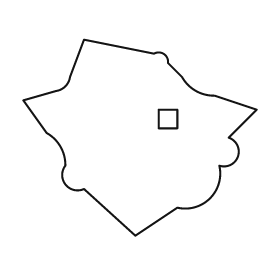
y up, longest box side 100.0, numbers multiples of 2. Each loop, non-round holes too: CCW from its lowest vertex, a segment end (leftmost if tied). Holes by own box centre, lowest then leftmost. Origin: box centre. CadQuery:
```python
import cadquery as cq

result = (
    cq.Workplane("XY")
    .moveTo(-2.0, -42.0)
    .lineTo(16.0, -30.0)
    .threePointArc((30.0, -26.0), (34.0, -12.0))
    .threePointArc((42.0, -8.0), (38.0, 0.0))
    .lineTo(50.0, 12.0)
    .lineTo(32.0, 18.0)
    .threePointArc((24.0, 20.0), (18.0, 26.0))
    .lineTo(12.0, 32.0)
    .threePointArc((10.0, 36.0), (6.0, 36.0))
    .lineTo(-24.0, 42.0)
    .lineTo(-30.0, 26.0)
    .threePointArc((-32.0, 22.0), (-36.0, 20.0))
    .lineTo(-50.0, 16.0)
    .lineTo(-40.0, 2.0)
    .threePointArc((-34.0, -4.0), (-32.0, -12.0))
    .threePointArc((-32.0, -20.0), (-24.0, -22.0))
    .close()
    .moveTo(8.0, 4.0)
    .lineTo(16.0, 4.0)
    .lineTo(16.0, 12.0)
    .lineTo(8.0, 12.0)
    .close()
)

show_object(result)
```